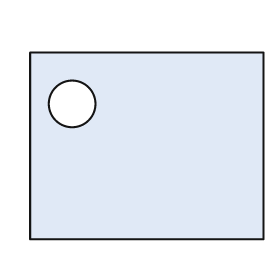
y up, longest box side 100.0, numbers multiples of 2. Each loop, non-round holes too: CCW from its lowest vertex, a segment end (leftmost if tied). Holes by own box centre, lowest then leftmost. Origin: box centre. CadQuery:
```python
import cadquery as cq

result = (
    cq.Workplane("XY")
    .moveTo(-50.0, -40.0)
    .lineTo(50.0, -40.0)
    .lineTo(50.0, 40.0)
    .lineTo(-50.0, 40.0)
    .close()
    .moveTo(-32.0, 18.0)
    .circle(10.0)
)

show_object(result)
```